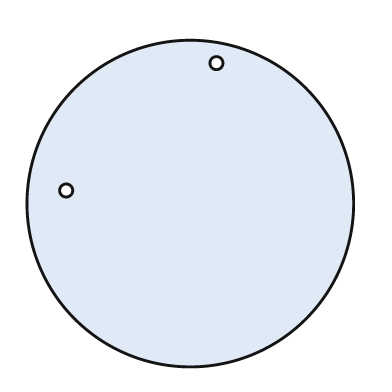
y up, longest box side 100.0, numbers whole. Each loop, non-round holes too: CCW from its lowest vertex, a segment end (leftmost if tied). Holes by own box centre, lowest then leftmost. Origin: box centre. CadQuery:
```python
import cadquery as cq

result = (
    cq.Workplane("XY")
    .moveTo(0.0, 0.0)
    .circle(50.0)
    .moveTo(-38.0, 4.0)
    .circle(2.0)
    .moveTo(8.0, 43.0)
    .circle(2.0)
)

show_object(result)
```